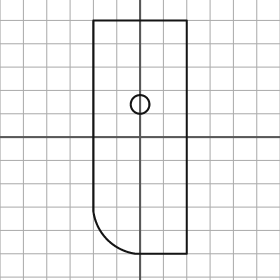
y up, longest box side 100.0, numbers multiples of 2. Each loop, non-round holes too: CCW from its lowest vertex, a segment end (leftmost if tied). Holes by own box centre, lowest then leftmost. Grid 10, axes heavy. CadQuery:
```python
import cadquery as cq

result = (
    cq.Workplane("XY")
    .moveTo(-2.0, -50.0)
    .lineTo(20.0, -50.0)
    .lineTo(20.0, 50.0)
    .lineTo(-20.0, 50.0)
    .lineTo(-20.0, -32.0)
    .threePointArc((-14.0, -44.0), (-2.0, -50.0))
    .close()
    .moveTo(0.0, 14.0)
    .circle(4.0)
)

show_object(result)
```